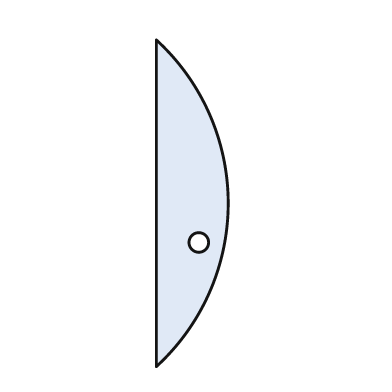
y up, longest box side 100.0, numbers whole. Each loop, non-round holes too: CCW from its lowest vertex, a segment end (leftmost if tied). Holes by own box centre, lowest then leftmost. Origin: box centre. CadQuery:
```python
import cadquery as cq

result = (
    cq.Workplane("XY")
    .moveTo(-11.0, -50.0)
    .threePointArc((11.0, 0.0), (-11.0, 50.0))
    .close()
    .moveTo(2.0, -12.0)
    .circle(3.0)
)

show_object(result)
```